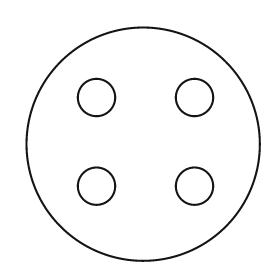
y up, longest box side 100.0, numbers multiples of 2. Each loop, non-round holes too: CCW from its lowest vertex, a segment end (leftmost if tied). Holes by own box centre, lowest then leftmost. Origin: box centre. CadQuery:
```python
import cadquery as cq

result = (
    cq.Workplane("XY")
    .moveTo(0.0, 0.0)
    .circle(50.0)
    .moveTo(-20.0, -18.0)
    .circle(8.0)
    .moveTo(22.0, -18.0)
    .circle(8.0)
    .moveTo(-20.0, 20.0)
    .circle(8.0)
    .moveTo(22.0, 20.0)
    .circle(8.0)
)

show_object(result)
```